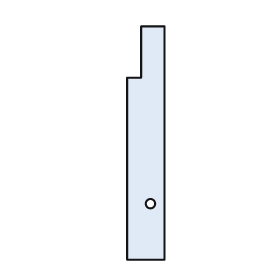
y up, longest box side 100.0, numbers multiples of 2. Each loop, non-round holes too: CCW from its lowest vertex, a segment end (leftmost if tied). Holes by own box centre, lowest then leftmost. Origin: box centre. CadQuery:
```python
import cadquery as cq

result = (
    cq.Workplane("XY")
    .moveTo(-8.0, -50.0)
    .lineTo(8.0, -50.0)
    .lineTo(8.0, 50.0)
    .lineTo(-2.0, 50.0)
    .lineTo(-2.0, 28.0)
    .lineTo(-8.0, 28.0)
    .close()
    .moveTo(2.0, -26.0)
    .circle(2.0)
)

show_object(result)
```